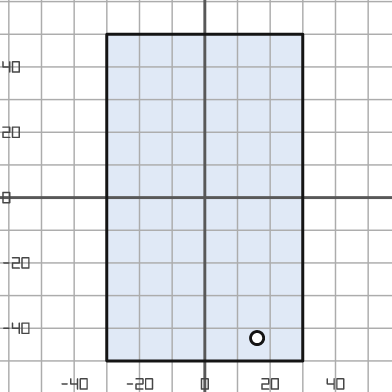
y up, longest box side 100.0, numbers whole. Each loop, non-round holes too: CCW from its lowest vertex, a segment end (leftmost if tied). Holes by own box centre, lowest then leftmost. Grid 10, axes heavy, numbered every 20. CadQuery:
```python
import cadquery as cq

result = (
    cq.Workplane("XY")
    .moveTo(-30.0, -50.0)
    .lineTo(30.0, -50.0)
    .lineTo(30.0, 50.0)
    .lineTo(-30.0, 50.0)
    .close()
    .moveTo(16.0, -43.0)
    .circle(2.0)
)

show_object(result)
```